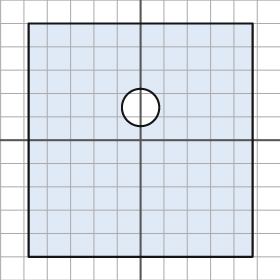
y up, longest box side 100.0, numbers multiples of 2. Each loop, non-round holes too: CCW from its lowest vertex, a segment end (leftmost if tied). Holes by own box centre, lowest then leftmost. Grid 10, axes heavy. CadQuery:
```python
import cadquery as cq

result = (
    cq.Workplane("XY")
    .moveTo(-48.0, -50.0)
    .lineTo(48.0, -50.0)
    .lineTo(48.0, 50.0)
    .lineTo(-48.0, 50.0)
    .close()
    .moveTo(0.0, 14.0)
    .circle(8.0)
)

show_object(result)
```